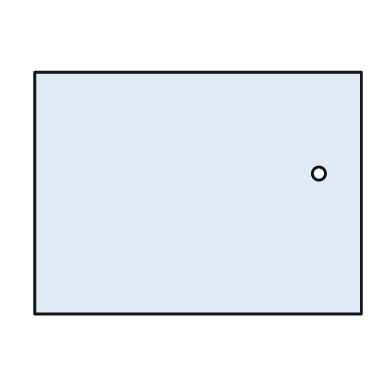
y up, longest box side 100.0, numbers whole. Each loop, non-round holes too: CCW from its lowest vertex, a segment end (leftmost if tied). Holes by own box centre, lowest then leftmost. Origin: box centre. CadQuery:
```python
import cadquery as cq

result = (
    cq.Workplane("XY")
    .moveTo(-50.0, -37.0)
    .lineTo(50.0, -37.0)
    .lineTo(50.0, 37.0)
    .lineTo(-50.0, 37.0)
    .close()
    .moveTo(37.0, 6.0)
    .circle(2.0)
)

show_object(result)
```